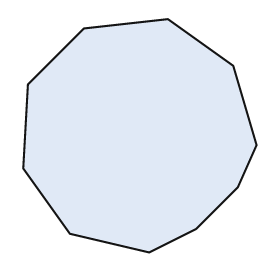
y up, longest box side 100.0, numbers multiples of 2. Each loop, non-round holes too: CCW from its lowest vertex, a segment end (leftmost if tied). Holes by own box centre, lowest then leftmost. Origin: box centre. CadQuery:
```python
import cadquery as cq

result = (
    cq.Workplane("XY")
    .moveTo(4.0, -50.0)
    .lineTo(24.0, -40.0)
    .lineTo(42.0, -22.0)
    .lineTo(50.0, -4.0)
    .lineTo(40.0, 30.0)
    .lineTo(12.0, 50.0)
    .lineTo(-24.0, 46.0)
    .lineTo(-48.0, 22.0)
    .lineTo(-50.0, -14.0)
    .lineTo(-30.0, -42.0)
    .close()
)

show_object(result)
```